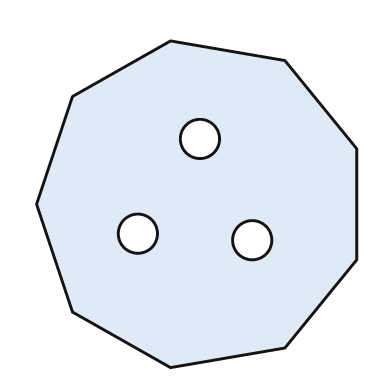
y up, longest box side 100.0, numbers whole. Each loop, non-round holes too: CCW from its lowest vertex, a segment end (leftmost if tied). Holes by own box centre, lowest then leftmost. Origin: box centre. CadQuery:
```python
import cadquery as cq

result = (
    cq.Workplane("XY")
    .moveTo(-8.0, -50.0)
    .lineTo(27.0, -44.0)
    .lineTo(49.0, -17.0)
    .lineTo(49.0, 17.0)
    .lineTo(27.0, 44.0)
    .lineTo(-8.0, 50.0)
    .lineTo(-38.0, 33.0)
    .lineTo(-49.0, 0.0)
    .lineTo(-38.0, -33.0)
    .close()
    .moveTo(17.0, -11.0)
    .circle(6.0)
    .moveTo(-18.0, -9.0)
    .circle(6.0)
    .moveTo(1.0, 20.0)
    .circle(6.0)
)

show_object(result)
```